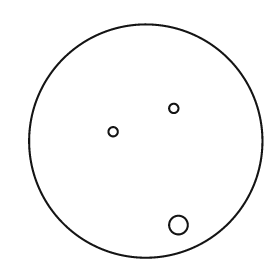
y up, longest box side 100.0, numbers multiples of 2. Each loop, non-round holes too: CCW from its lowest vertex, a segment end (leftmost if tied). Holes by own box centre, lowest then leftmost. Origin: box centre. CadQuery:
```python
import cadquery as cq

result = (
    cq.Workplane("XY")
    .moveTo(0.0, 0.0)
    .circle(50.0)
    .moveTo(14.0, -36.0)
    .circle(4.0)
    .moveTo(-14.0, 4.0)
    .circle(2.0)
    .moveTo(12.0, 14.0)
    .circle(2.0)
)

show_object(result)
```